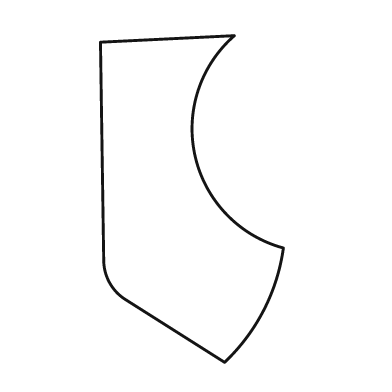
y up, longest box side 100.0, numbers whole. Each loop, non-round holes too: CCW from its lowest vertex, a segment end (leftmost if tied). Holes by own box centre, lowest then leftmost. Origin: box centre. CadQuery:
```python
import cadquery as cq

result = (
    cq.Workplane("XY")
    .moveTo(10.0, -50.0)
    .threePointArc((22.0, -34.0), (28.0, -15.0))
    .threePointArc((1.0, 13.0), (13.0, 50.0))
    .lineTo(-28.0, 48.0)
    .lineTo(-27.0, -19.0)
    .threePointArc((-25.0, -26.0), (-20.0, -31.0))
    .close()
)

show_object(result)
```